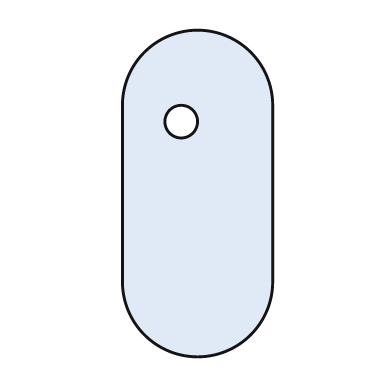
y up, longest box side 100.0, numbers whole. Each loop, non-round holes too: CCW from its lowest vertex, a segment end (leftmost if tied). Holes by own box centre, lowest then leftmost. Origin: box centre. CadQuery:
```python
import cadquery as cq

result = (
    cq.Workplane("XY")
    .moveTo(-23.0, -27.0)
    .threePointArc((0.0, -50.0), (23.0, -27.0))
    .lineTo(23.0, 27.0)
    .threePointArc((0.0, 50.0), (-23.0, 27.0))
    .close()
    .moveTo(-5.0, 22.0)
    .circle(5.0)
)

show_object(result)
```